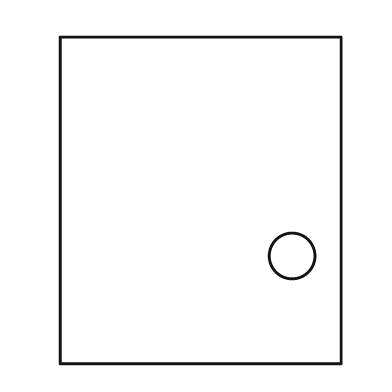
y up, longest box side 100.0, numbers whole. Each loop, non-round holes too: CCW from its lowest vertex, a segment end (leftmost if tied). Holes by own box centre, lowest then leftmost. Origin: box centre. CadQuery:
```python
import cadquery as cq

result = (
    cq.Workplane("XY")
    .moveTo(-43.0, -50.0)
    .lineTo(43.0, -50.0)
    .lineTo(43.0, 50.0)
    .lineTo(-43.0, 50.0)
    .close()
    .moveTo(28.0, -17.0)
    .circle(7.0)
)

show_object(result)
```